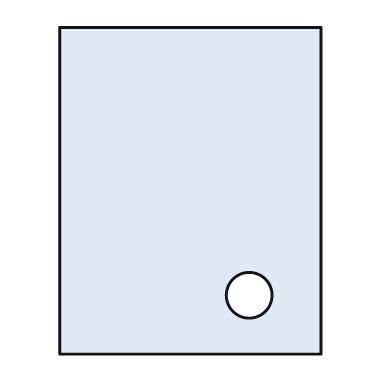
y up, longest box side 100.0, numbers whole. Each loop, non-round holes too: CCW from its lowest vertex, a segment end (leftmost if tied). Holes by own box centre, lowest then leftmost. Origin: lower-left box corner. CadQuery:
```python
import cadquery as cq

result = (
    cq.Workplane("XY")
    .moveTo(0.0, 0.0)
    .lineTo(80.0, 0.0)
    .lineTo(80.0, 100.0)
    .lineTo(0.0, 100.0)
    .close()
    .moveTo(58.0, 18.0)
    .circle(7.0)
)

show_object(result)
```